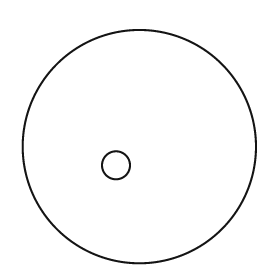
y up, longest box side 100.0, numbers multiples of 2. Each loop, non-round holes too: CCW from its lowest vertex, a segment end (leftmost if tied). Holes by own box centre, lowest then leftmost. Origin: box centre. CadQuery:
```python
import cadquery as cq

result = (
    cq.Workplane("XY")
    .moveTo(0.0, 0.0)
    .circle(50.0)
    .moveTo(-10.0, -8.0)
    .circle(6.0)
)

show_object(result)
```